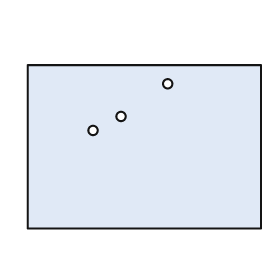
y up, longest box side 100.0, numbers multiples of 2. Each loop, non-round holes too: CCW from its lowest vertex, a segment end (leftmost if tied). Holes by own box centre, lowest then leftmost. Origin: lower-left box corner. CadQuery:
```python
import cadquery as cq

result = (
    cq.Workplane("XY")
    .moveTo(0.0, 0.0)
    .lineTo(100.0, 0.0)
    .lineTo(100.0, 70.0)
    .lineTo(0.0, 70.0)
    .close()
    .moveTo(28.0, 42.0)
    .circle(2.0)
    .moveTo(40.0, 48.0)
    .circle(2.0)
    .moveTo(60.0, 62.0)
    .circle(2.0)
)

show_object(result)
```